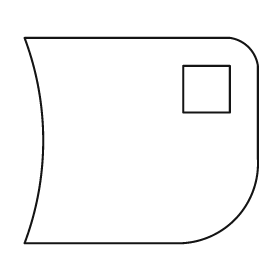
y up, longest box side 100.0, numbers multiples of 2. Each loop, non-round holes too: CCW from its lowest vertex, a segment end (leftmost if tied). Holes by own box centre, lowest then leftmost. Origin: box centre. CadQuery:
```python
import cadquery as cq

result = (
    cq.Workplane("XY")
    .moveTo(-50.0, -44.0)
    .lineTo(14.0, -44.0)
    .threePointArc((40.0, -34.0), (50.0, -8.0))
    .lineTo(50.0, 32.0)
    .threePointArc((46.0, 40.0), (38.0, 44.0))
    .lineTo(-50.0, 44.0)
    .threePointArc((-42.0, 0.0), (-50.0, -44.0))
    .close()
    .moveTo(18.0, 12.0)
    .lineTo(38.0, 12.0)
    .lineTo(38.0, 32.0)
    .lineTo(18.0, 32.0)
    .close()
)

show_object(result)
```